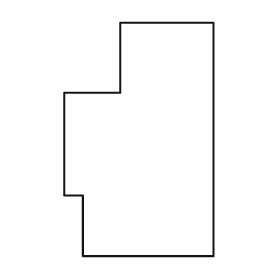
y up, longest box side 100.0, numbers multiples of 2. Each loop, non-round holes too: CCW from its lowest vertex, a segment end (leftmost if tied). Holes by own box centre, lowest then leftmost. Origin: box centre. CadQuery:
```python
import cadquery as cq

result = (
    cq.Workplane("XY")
    .moveTo(-24.0, -50.0)
    .lineTo(32.0, -50.0)
    .lineTo(32.0, 50.0)
    .lineTo(-8.0, 50.0)
    .lineTo(-8.0, 20.0)
    .lineTo(-32.0, 20.0)
    .lineTo(-32.0, -24.0)
    .lineTo(-24.0, -24.0)
    .close()
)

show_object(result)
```